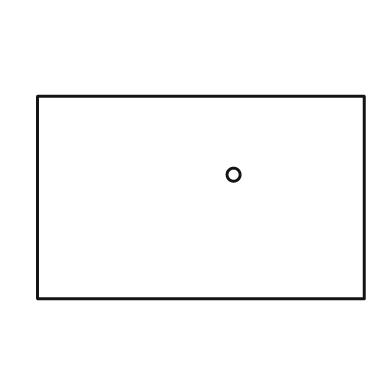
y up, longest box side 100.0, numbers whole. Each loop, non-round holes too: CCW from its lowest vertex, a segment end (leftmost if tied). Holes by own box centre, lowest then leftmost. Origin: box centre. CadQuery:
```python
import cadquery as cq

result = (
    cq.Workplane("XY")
    .moveTo(-50.0, -31.0)
    .lineTo(50.0, -31.0)
    .lineTo(50.0, 31.0)
    .lineTo(-50.0, 31.0)
    .close()
    .moveTo(10.0, 7.0)
    .circle(2.0)
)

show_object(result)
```